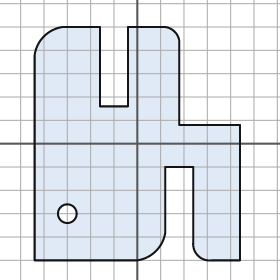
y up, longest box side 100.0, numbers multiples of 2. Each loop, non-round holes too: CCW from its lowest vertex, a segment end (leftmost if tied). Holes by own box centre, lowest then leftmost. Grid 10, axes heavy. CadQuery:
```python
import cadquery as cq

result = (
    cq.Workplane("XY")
    .moveTo(-44.0, -50.0)
    .lineTo(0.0, -50.0)
    .threePointArc((8.0, -46.0), (12.0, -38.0))
    .lineTo(12.0, -10.0)
    .lineTo(24.0, -10.0)
    .lineTo(24.0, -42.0)
    .threePointArc((26.0, -48.0), (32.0, -50.0))
    .lineTo(44.0, -50.0)
    .lineTo(44.0, 8.0)
    .lineTo(18.0, 8.0)
    .lineTo(18.0, 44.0)
    .threePointArc((16.0, 48.0), (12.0, 50.0))
    .lineTo(-4.0, 50.0)
    .lineTo(-4.0, 16.0)
    .lineTo(-16.0, 16.0)
    .lineTo(-16.0, 50.0)
    .lineTo(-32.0, 50.0)
    .threePointArc((-40.0, 46.0), (-44.0, 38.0))
    .close()
    .moveTo(-30.0, -30.0)
    .circle(4.0)
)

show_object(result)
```